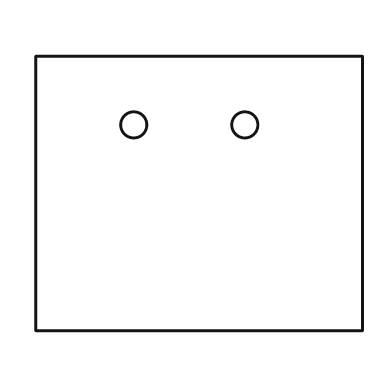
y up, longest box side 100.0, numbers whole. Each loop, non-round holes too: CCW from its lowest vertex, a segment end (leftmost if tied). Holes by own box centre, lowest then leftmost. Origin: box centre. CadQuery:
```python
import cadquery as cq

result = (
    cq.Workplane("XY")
    .moveTo(-50.0, -42.0)
    .lineTo(50.0, -42.0)
    .lineTo(50.0, 42.0)
    .lineTo(-50.0, 42.0)
    .close()
    .moveTo(-20.0, 21.0)
    .circle(4.0)
    .moveTo(14.0, 21.0)
    .circle(4.0)
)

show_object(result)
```